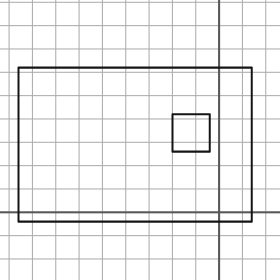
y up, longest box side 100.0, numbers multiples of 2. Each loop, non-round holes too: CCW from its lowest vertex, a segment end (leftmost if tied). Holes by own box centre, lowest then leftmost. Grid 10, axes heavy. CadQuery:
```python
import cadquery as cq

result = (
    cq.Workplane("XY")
    .moveTo(-86.0, -4.0)
    .lineTo(14.0, -4.0)
    .lineTo(14.0, 62.0)
    .lineTo(-86.0, 62.0)
    .close()
    .moveTo(-20.0, 26.0)
    .lineTo(-4.0, 26.0)
    .lineTo(-4.0, 42.0)
    .lineTo(-20.0, 42.0)
    .close()
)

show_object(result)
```